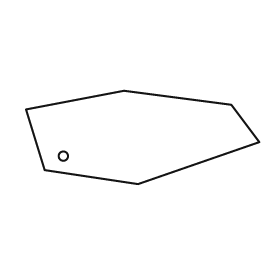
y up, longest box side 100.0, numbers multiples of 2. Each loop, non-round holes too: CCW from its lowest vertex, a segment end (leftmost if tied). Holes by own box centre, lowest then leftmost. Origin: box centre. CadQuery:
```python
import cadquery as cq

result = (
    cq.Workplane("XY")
    .moveTo(-2.0, -20.0)
    .lineTo(50.0, -2.0)
    .lineTo(38.0, 14.0)
    .lineTo(-8.0, 20.0)
    .lineTo(-50.0, 12.0)
    .lineTo(-42.0, -14.0)
    .close()
    .moveTo(-34.0, -8.0)
    .circle(2.0)
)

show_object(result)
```